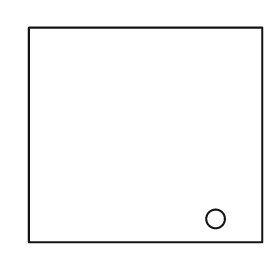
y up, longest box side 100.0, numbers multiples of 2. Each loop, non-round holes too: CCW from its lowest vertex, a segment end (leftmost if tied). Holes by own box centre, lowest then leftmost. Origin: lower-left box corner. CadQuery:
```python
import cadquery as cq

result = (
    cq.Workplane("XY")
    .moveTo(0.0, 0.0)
    .lineTo(100.0, 0.0)
    .lineTo(100.0, 92.0)
    .lineTo(0.0, 92.0)
    .close()
    .moveTo(80.0, 10.0)
    .circle(4.0)
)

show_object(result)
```